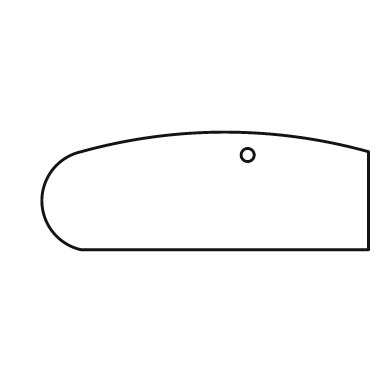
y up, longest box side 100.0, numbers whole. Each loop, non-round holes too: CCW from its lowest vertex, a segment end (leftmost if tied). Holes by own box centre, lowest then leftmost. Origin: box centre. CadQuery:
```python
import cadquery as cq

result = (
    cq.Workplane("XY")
    .moveTo(-38.0, -18.0)
    .lineTo(50.0, -18.0)
    .lineTo(50.0, 12.0)
    .threePointArc((6.0, 18.0), (-38.0, 12.0))
    .threePointArc((-50.0, -3.0), (-38.0, -18.0))
    .close()
    .moveTo(13.0, 11.0)
    .circle(2.0)
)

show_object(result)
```